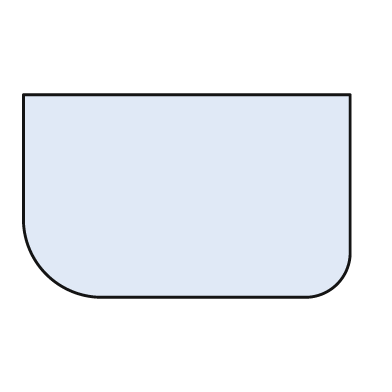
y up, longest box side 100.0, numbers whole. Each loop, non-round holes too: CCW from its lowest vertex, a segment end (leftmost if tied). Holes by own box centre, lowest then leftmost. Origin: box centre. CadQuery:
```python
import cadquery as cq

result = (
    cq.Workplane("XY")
    .moveTo(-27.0, -31.0)
    .lineTo(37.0, -31.0)
    .threePointArc((46.0, -27.0), (50.0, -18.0))
    .lineTo(50.0, 31.0)
    .lineTo(-50.0, 31.0)
    .lineTo(-50.0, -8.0)
    .threePointArc((-43.0, -24.0), (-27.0, -31.0))
    .close()
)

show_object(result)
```